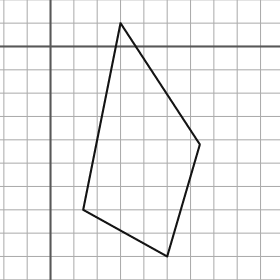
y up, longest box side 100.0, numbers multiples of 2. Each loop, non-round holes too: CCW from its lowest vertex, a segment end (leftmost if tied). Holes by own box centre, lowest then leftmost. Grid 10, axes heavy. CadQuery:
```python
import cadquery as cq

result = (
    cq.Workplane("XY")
    .moveTo(50.0, -90.0)
    .lineTo(64.0, -42.0)
    .lineTo(30.0, 10.0)
    .lineTo(14.0, -70.0)
    .close()
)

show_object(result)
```